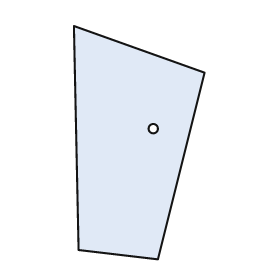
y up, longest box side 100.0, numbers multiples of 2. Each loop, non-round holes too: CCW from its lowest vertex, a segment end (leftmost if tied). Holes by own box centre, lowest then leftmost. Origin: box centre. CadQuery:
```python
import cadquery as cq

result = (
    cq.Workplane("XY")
    .moveTo(8.0, -50.0)
    .lineTo(28.0, 30.0)
    .lineTo(-28.0, 50.0)
    .lineTo(-26.0, -46.0)
    .close()
    .moveTo(6.0, 6.0)
    .circle(2.0)
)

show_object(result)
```